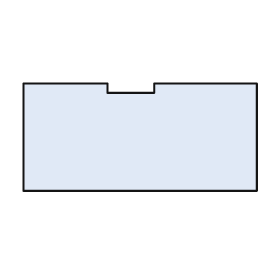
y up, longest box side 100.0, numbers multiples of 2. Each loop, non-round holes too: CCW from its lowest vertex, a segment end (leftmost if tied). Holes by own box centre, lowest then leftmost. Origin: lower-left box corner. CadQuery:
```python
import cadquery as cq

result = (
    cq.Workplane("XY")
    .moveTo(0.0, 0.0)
    .lineTo(100.0, 0.0)
    .lineTo(100.0, 46.0)
    .lineTo(56.0, 46.0)
    .lineTo(56.0, 42.0)
    .lineTo(36.0, 42.0)
    .lineTo(36.0, 46.0)
    .lineTo(0.0, 46.0)
    .close()
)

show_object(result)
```